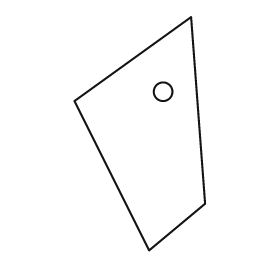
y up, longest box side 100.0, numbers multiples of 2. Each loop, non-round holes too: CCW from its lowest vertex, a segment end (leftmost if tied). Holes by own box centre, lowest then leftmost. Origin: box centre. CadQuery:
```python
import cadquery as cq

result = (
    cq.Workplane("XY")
    .moveTo(4.0, -50.0)
    .lineTo(28.0, -30.0)
    .lineTo(22.0, 50.0)
    .lineTo(-28.0, 14.0)
    .close()
    .moveTo(10.0, 18.0)
    .circle(4.0)
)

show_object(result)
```